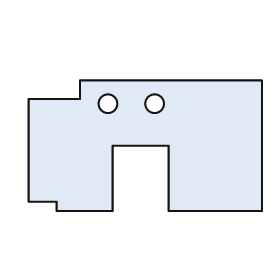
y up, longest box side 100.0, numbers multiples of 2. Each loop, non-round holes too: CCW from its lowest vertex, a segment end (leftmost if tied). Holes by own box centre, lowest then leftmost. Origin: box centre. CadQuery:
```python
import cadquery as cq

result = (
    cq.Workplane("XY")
    .moveTo(-38.0, -28.0)
    .lineTo(-14.0, -28.0)
    .lineTo(-14.0, 0.0)
    .lineTo(10.0, 0.0)
    .lineTo(10.0, -28.0)
    .lineTo(50.0, -28.0)
    .lineTo(50.0, 28.0)
    .lineTo(-28.0, 28.0)
    .lineTo(-28.0, 20.0)
    .lineTo(-50.0, 20.0)
    .lineTo(-50.0, -24.0)
    .lineTo(-38.0, -24.0)
    .close()
    .moveTo(-16.0, 18.0)
    .circle(4.0)
    .moveTo(4.0, 18.0)
    .circle(4.0)
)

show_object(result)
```